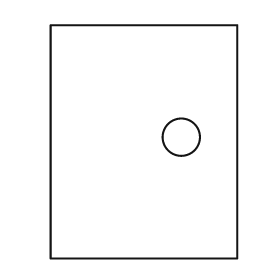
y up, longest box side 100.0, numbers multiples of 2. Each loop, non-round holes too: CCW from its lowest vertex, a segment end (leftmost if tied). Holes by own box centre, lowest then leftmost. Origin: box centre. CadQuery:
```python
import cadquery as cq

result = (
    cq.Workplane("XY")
    .moveTo(-40.0, -50.0)
    .lineTo(40.0, -50.0)
    .lineTo(40.0, 50.0)
    .lineTo(-40.0, 50.0)
    .close()
    .moveTo(16.0, 2.0)
    .circle(8.0)
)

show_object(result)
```